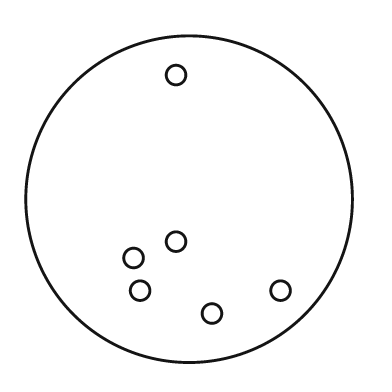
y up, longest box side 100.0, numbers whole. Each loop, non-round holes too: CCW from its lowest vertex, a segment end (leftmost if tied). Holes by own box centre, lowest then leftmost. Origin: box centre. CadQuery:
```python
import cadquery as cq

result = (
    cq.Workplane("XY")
    .moveTo(0.0, 0.0)
    .circle(50.0)
    .moveTo(7.0, -35.0)
    .circle(3.0)
    .moveTo(-15.0, -28.0)
    .circle(3.0)
    .moveTo(28.0, -28.0)
    .circle(3.0)
    .moveTo(-17.0, -18.0)
    .circle(3.0)
    .moveTo(-4.0, -13.0)
    .circle(3.0)
    .moveTo(-4.0, 38.0)
    .circle(3.0)
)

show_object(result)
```